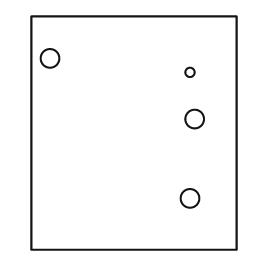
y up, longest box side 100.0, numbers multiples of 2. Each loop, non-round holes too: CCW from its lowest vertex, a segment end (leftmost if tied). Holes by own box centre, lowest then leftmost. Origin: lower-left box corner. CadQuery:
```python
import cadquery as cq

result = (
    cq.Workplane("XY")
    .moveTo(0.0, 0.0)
    .lineTo(88.0, 0.0)
    .lineTo(88.0, 100.0)
    .lineTo(0.0, 100.0)
    .close()
    .moveTo(68.0, 22.0)
    .circle(4.0)
    .moveTo(70.0, 56.0)
    .circle(4.0)
    .moveTo(68.0, 76.0)
    .circle(2.0)
    .moveTo(8.0, 82.0)
    .circle(4.0)
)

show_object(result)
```